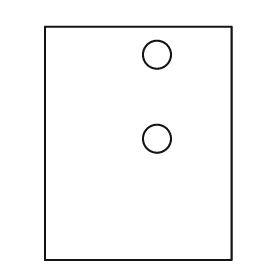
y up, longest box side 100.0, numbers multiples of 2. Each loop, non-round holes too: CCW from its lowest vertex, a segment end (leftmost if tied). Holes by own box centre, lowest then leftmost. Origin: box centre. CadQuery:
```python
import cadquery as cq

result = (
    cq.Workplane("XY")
    .moveTo(-40.0, -50.0)
    .lineTo(40.0, -50.0)
    .lineTo(40.0, 50.0)
    .lineTo(-40.0, 50.0)
    .close()
    .moveTo(8.0, 2.0)
    .circle(6.0)
    .moveTo(8.0, 38.0)
    .circle(6.0)
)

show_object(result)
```